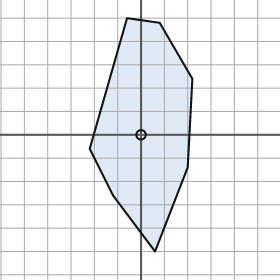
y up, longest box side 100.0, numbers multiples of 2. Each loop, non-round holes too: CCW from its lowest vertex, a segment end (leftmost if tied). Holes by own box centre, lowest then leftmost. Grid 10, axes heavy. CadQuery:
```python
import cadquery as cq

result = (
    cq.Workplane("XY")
    .moveTo(6.0, -50.0)
    .lineTo(20.0, -14.0)
    .lineTo(22.0, 24.0)
    .lineTo(8.0, 48.0)
    .lineTo(-6.0, 50.0)
    .lineTo(-22.0, -6.0)
    .lineTo(-12.0, -26.0)
    .close()
    .moveTo(0.0, 0.0)
    .circle(2.0)
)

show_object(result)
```